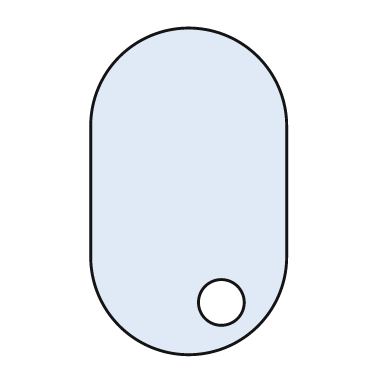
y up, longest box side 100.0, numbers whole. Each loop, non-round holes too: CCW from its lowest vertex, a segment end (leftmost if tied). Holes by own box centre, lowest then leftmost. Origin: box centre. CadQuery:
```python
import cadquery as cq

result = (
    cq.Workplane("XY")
    .moveTo(-30.0, -20.0)
    .threePointArc((0.0, -50.0), (30.0, -20.0))
    .lineTo(30.0, 20.0)
    .threePointArc((0.0, 50.0), (-30.0, 20.0))
    .close()
    .moveTo(10.0, -34.0)
    .circle(7.0)
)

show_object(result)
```